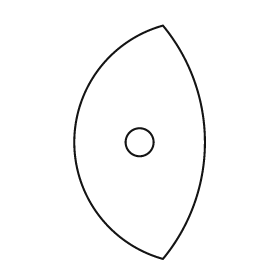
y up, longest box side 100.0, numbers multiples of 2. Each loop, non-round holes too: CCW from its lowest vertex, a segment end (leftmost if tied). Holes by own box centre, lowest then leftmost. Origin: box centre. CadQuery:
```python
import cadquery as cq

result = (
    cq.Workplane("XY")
    .moveTo(10.0, -50.0)
    .threePointArc((28.0, 0.0), (10.0, 50.0))
    .threePointArc((-28.0, 0.0), (10.0, -50.0))
    .close()
    .moveTo(0.0, 0.0)
    .circle(6.0)
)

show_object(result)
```